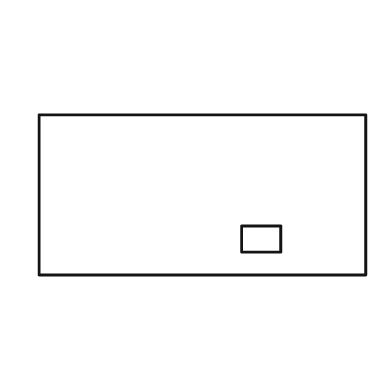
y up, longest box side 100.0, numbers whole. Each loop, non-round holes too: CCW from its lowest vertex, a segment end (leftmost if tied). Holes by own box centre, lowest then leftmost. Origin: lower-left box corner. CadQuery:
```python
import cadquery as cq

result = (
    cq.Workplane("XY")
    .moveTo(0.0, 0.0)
    .lineTo(100.0, 0.0)
    .lineTo(100.0, 49.0)
    .lineTo(0.0, 49.0)
    .close()
    .moveTo(62.0, 7.0)
    .lineTo(74.0, 7.0)
    .lineTo(74.0, 15.0)
    .lineTo(62.0, 15.0)
    .close()
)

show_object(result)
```